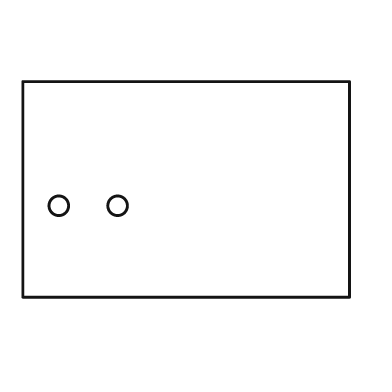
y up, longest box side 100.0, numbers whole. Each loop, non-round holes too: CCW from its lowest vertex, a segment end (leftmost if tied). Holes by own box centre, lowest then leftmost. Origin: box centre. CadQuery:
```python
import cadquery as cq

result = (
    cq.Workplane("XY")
    .moveTo(-50.0, -33.0)
    .lineTo(50.0, -33.0)
    .lineTo(50.0, 33.0)
    .lineTo(-50.0, 33.0)
    .close()
    .moveTo(-39.0, -5.0)
    .circle(3.0)
    .moveTo(-21.0, -5.0)
    .circle(3.0)
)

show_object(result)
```